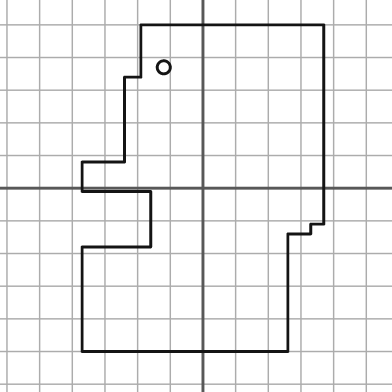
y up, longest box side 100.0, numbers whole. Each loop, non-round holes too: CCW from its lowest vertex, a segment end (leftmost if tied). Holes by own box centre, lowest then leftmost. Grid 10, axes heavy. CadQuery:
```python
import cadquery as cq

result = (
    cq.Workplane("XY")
    .moveTo(-37.0, -50.0)
    .lineTo(26.0, -50.0)
    .lineTo(26.0, -14.0)
    .lineTo(33.0, -14.0)
    .lineTo(33.0, -11.0)
    .lineTo(37.0, -11.0)
    .lineTo(37.0, 50.0)
    .lineTo(-19.0, 50.0)
    .lineTo(-19.0, 34.0)
    .lineTo(-24.0, 34.0)
    .lineTo(-24.0, 8.0)
    .lineTo(-37.0, 8.0)
    .lineTo(-37.0, -1.0)
    .lineTo(-16.0, -1.0)
    .lineTo(-16.0, -18.0)
    .lineTo(-37.0, -18.0)
    .close()
    .moveTo(-12.0, 37.0)
    .circle(2.0)
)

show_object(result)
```